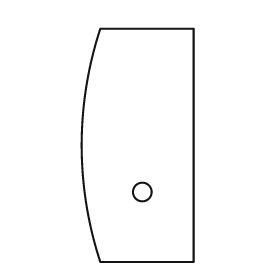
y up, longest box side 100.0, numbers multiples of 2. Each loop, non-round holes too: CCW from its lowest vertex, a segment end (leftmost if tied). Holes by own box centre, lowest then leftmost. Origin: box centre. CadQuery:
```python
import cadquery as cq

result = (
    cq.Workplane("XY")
    .moveTo(-16.0, -50.0)
    .lineTo(24.0, -50.0)
    .lineTo(24.0, 50.0)
    .lineTo(-16.0, 50.0)
    .threePointArc((-24.0, 0.0), (-16.0, -50.0))
    .close()
    .moveTo(2.0, -20.0)
    .circle(4.0)
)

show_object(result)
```